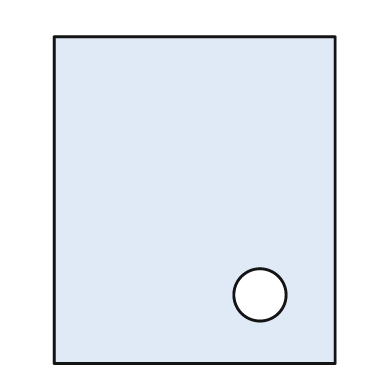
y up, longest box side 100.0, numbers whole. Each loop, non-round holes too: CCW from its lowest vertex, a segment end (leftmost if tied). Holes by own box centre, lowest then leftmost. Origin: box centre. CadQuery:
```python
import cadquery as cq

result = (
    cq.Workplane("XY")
    .moveTo(-43.0, -50.0)
    .lineTo(43.0, -50.0)
    .lineTo(43.0, 50.0)
    .lineTo(-43.0, 50.0)
    .close()
    .moveTo(20.0, -29.0)
    .circle(8.0)
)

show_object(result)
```